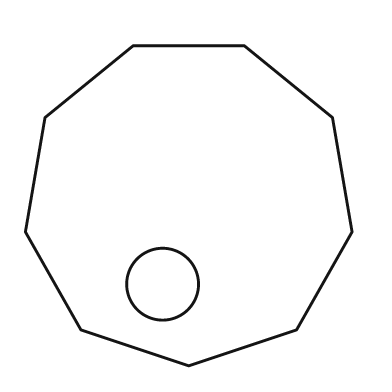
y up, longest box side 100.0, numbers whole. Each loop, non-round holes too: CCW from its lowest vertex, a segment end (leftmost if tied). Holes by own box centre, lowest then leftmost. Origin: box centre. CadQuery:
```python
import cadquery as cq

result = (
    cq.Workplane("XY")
    .moveTo(0.0, -49.0)
    .lineTo(33.0, -38.0)
    .lineTo(50.0, -8.0)
    .lineTo(44.0, 27.0)
    .lineTo(17.0, 49.0)
    .lineTo(-17.0, 49.0)
    .lineTo(-44.0, 27.0)
    .lineTo(-50.0, -8.0)
    .lineTo(-33.0, -38.0)
    .close()
    .moveTo(-8.0, -24.0)
    .circle(11.0)
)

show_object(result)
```